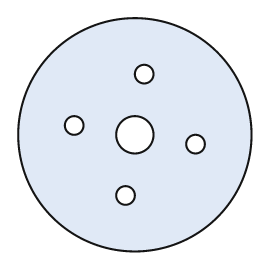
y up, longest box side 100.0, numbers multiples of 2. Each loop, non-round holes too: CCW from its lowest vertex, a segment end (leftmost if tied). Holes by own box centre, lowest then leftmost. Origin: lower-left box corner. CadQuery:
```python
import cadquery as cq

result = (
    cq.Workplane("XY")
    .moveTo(50.0, 50.0)
    .circle(50.0)
    .moveTo(46.0, 24.0)
    .circle(4.0)
    .moveTo(76.0, 46.0)
    .circle(4.0)
    .moveTo(50.0, 50.0)
    .circle(8.0)
    .moveTo(24.0, 54.0)
    .circle(4.0)
    .moveTo(54.0, 76.0)
    .circle(4.0)
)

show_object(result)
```